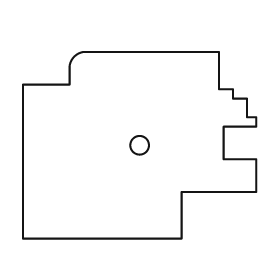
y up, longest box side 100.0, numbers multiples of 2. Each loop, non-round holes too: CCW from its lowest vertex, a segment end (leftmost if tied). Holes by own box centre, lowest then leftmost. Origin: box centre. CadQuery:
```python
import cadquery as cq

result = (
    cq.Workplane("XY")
    .moveTo(-50.0, -40.0)
    .lineTo(18.0, -40.0)
    .lineTo(18.0, -20.0)
    .lineTo(50.0, -20.0)
    .lineTo(50.0, -6.0)
    .lineTo(36.0, -6.0)
    .lineTo(36.0, 8.0)
    .lineTo(50.0, 8.0)
    .lineTo(50.0, 12.0)
    .lineTo(46.0, 12.0)
    .lineTo(46.0, 20.0)
    .lineTo(40.0, 20.0)
    .lineTo(40.0, 24.0)
    .lineTo(34.0, 24.0)
    .lineTo(34.0, 40.0)
    .lineTo(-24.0, 40.0)
    .threePointArc((-28.0, 38.0), (-30.0, 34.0))
    .lineTo(-30.0, 26.0)
    .lineTo(-50.0, 26.0)
    .close()
    .moveTo(0.0, 0.0)
    .circle(4.0)
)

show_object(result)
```